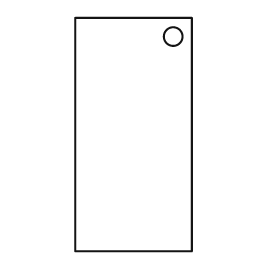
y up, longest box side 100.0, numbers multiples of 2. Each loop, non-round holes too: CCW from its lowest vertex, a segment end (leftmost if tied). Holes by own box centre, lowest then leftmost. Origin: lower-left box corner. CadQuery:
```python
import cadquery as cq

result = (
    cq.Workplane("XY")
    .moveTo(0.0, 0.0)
    .lineTo(50.0, 0.0)
    .lineTo(50.0, 100.0)
    .lineTo(0.0, 100.0)
    .close()
    .moveTo(42.0, 92.0)
    .circle(4.0)
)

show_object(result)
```